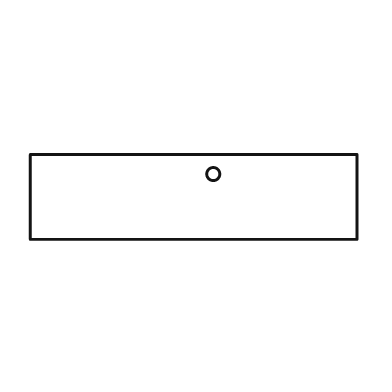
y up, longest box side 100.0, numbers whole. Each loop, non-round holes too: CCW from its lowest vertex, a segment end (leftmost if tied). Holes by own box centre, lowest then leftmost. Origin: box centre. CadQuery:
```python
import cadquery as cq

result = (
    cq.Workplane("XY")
    .moveTo(-50.0, -13.0)
    .lineTo(50.0, -13.0)
    .lineTo(50.0, 13.0)
    .lineTo(-50.0, 13.0)
    .close()
    .moveTo(6.0, 7.0)
    .circle(2.0)
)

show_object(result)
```